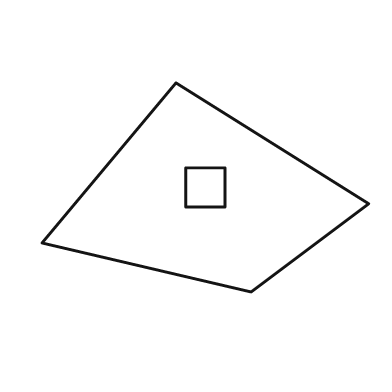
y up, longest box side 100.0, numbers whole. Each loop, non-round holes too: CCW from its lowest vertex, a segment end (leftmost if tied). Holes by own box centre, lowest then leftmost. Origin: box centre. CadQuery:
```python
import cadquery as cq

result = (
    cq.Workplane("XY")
    .moveTo(14.0, -32.0)
    .lineTo(50.0, -5.0)
    .lineTo(-9.0, 32.0)
    .lineTo(-50.0, -17.0)
    .close()
    .moveTo(-6.0, -6.0)
    .lineTo(6.0, -6.0)
    .lineTo(6.0, 6.0)
    .lineTo(-6.0, 6.0)
    .close()
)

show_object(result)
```